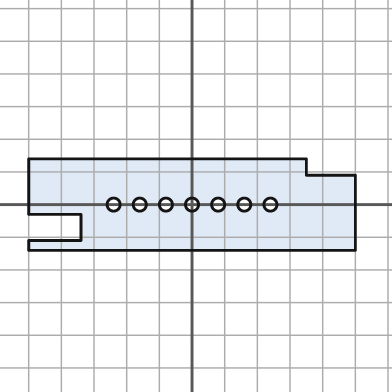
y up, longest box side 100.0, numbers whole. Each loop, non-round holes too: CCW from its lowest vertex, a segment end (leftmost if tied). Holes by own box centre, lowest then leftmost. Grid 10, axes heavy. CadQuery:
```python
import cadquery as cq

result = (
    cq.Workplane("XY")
    .moveTo(-50.0, -14.0)
    .lineTo(50.0, -14.0)
    .lineTo(50.0, 9.0)
    .lineTo(35.0, 9.0)
    .lineTo(35.0, 14.0)
    .lineTo(-50.0, 14.0)
    .lineTo(-50.0, -3.0)
    .lineTo(-34.0, -3.0)
    .lineTo(-34.0, -11.0)
    .lineTo(-50.0, -11.0)
    .close()
    .moveTo(-24.0, 0.0)
    .circle(2.0)
    .moveTo(-16.0, 0.0)
    .circle(2.0)
    .moveTo(-8.0, 0.0)
    .circle(2.0)
    .moveTo(0.0, 0.0)
    .circle(2.0)
    .moveTo(8.0, 0.0)
    .circle(2.0)
    .moveTo(16.0, 0.0)
    .circle(2.0)
    .moveTo(24.0, 0.0)
    .circle(2.0)
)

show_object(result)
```